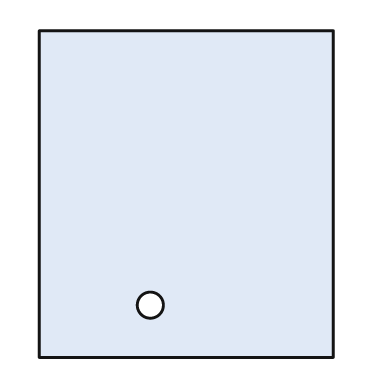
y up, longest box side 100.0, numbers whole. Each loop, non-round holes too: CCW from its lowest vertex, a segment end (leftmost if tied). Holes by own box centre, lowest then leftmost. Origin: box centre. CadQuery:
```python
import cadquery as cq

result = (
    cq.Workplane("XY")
    .moveTo(-45.0, -50.0)
    .lineTo(45.0, -50.0)
    .lineTo(45.0, 50.0)
    .lineTo(-45.0, 50.0)
    .close()
    .moveTo(-11.0, -34.0)
    .circle(4.0)
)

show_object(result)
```